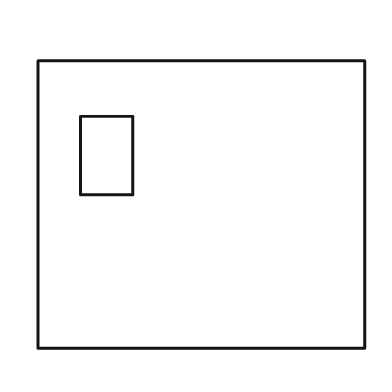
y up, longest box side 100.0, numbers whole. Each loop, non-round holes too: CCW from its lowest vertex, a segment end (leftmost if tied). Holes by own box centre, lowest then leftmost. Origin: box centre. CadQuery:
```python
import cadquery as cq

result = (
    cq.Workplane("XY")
    .moveTo(-50.0, -44.0)
    .lineTo(50.0, -44.0)
    .lineTo(50.0, 44.0)
    .lineTo(-50.0, 44.0)
    .close()
    .moveTo(-37.0, 3.0)
    .lineTo(-21.0, 3.0)
    .lineTo(-21.0, 27.0)
    .lineTo(-37.0, 27.0)
    .close()
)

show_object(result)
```